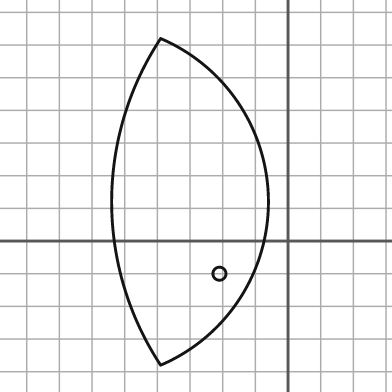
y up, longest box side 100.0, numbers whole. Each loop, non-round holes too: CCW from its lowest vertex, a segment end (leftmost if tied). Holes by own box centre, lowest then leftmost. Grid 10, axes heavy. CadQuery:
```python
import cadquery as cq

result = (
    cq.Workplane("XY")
    .moveTo(-39.0, -38.0)
    .threePointArc((-6.0, 12.0), (-39.0, 62.0))
    .threePointArc((-54.0, 12.0), (-39.0, -38.0))
    .close()
    .moveTo(-21.0, -10.0)
    .circle(2.0)
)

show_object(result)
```